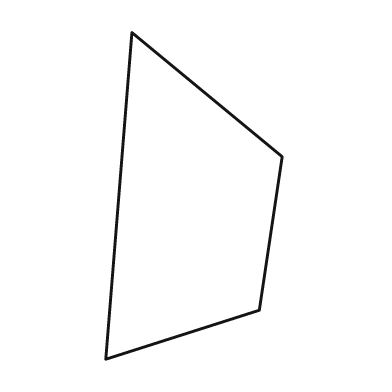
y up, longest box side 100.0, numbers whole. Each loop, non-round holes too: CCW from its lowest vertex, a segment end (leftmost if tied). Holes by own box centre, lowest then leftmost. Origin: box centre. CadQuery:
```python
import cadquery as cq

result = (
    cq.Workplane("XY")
    .moveTo(-27.0, -50.0)
    .lineTo(20.0, -35.0)
    .lineTo(27.0, 12.0)
    .lineTo(-19.0, 50.0)
    .close()
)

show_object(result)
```